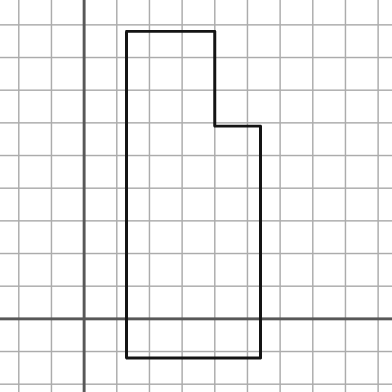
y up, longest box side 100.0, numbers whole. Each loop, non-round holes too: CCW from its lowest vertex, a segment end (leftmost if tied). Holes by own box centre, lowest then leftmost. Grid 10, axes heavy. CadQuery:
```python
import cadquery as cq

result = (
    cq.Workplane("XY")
    .moveTo(13.0, -12.0)
    .lineTo(54.0, -12.0)
    .lineTo(54.0, 59.0)
    .lineTo(40.0, 59.0)
    .lineTo(40.0, 88.0)
    .lineTo(13.0, 88.0)
    .close()
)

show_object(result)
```